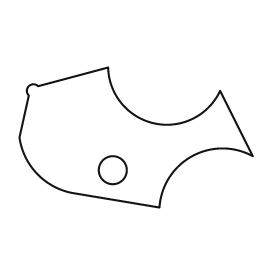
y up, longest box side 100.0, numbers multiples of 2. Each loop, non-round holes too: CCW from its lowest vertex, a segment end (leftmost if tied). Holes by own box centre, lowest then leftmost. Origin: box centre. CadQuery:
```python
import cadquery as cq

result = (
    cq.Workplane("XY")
    .moveTo(10.0, -30.0)
    .threePointArc((24.0, -8.0), (50.0, -8.0))
    .lineTo(36.0, 20.0)
    .threePointArc((8.0, 6.0), (-12.0, 30.0))
    .lineTo(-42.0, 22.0)
    .threePointArc((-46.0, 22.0), (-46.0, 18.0))
    .lineTo(-50.0, 0.0)
    .threePointArc((-42.0, -16.0), (-26.0, -24.0))
    .close()
    .moveTo(-10.0, -14.0)
    .circle(6.0)
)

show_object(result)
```